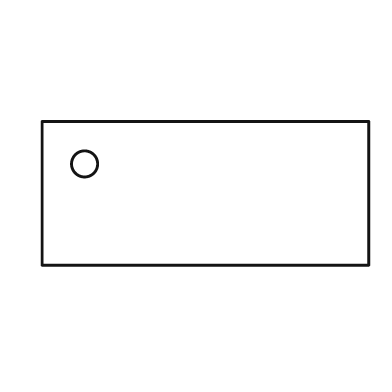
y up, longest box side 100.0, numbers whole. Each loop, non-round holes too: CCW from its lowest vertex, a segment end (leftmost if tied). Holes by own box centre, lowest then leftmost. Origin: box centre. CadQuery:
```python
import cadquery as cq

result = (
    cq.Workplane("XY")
    .moveTo(-50.0, -22.0)
    .lineTo(50.0, -22.0)
    .lineTo(50.0, 22.0)
    .lineTo(-50.0, 22.0)
    .close()
    .moveTo(-37.0, 9.0)
    .circle(4.0)
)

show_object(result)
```